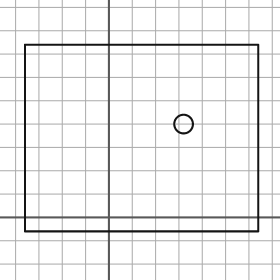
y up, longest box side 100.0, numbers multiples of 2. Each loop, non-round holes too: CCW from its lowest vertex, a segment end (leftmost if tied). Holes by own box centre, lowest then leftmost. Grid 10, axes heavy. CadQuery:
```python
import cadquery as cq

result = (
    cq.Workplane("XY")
    .moveTo(-36.0, -6.0)
    .lineTo(64.0, -6.0)
    .lineTo(64.0, 74.0)
    .lineTo(-36.0, 74.0)
    .close()
    .moveTo(32.0, 40.0)
    .circle(4.0)
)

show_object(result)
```